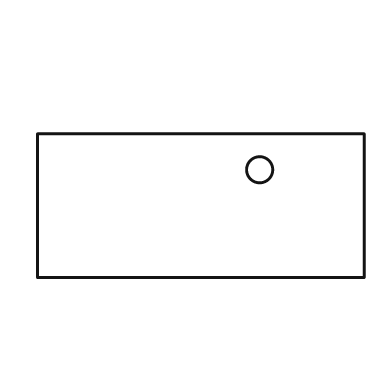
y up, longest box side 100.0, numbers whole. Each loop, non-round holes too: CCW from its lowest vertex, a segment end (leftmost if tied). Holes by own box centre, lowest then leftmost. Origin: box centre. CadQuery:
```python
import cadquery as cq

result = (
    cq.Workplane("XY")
    .moveTo(-50.0, -22.0)
    .lineTo(50.0, -22.0)
    .lineTo(50.0, 22.0)
    .lineTo(-50.0, 22.0)
    .close()
    .moveTo(18.0, 11.0)
    .circle(4.0)
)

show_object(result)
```